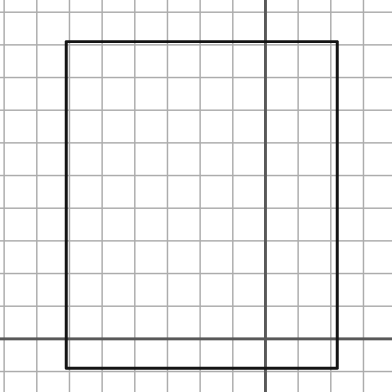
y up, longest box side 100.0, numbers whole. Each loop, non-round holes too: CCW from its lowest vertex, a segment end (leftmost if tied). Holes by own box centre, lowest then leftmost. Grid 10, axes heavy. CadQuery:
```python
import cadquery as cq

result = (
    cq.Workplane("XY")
    .moveTo(-61.0, -9.0)
    .lineTo(22.0, -9.0)
    .lineTo(22.0, 91.0)
    .lineTo(-61.0, 91.0)
    .close()
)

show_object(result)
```